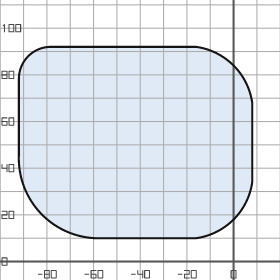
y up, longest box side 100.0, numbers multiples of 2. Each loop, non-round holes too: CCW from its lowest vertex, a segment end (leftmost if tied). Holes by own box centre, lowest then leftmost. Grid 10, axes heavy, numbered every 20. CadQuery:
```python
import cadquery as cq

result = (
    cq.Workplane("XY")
    .moveTo(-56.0, 10.0)
    .lineTo(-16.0, 10.0)
    .threePointArc((0.0, 18.0), (8.0, 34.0))
    .lineTo(8.0, 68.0)
    .threePointArc((0.0, 84.0), (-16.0, 92.0))
    .lineTo(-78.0, 92.0)
    .threePointArc((-88.0, 88.0), (-92.0, 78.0))
    .lineTo(-92.0, 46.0)
    .threePointArc((-82.0, 20.0), (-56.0, 10.0))
    .close()
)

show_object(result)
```